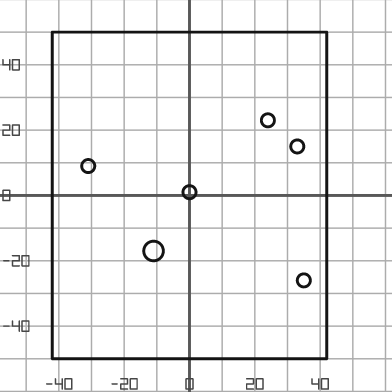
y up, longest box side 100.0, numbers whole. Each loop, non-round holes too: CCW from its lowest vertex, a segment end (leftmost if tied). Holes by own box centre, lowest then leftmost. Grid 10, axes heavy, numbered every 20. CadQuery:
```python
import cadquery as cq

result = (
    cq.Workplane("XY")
    .moveTo(-42.0, -50.0)
    .lineTo(42.0, -50.0)
    .lineTo(42.0, 50.0)
    .lineTo(-42.0, 50.0)
    .close()
    .moveTo(35.0, -26.0)
    .circle(2.0)
    .moveTo(-11.0, -17.0)
    .circle(3.0)
    .moveTo(0.0, 1.0)
    .circle(2.0)
    .moveTo(-31.0, 9.0)
    .circle(2.0)
    .moveTo(33.0, 15.0)
    .circle(2.0)
    .moveTo(24.0, 23.0)
    .circle(2.0)
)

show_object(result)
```